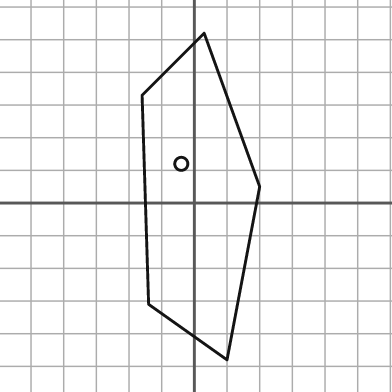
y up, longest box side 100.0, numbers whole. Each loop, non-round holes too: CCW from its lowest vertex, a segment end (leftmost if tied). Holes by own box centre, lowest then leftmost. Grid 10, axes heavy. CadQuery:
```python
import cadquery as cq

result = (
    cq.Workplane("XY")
    .moveTo(10.0, -48.0)
    .lineTo(20.0, 5.0)
    .lineTo(3.0, 52.0)
    .lineTo(-16.0, 33.0)
    .lineTo(-14.0, -31.0)
    .close()
    .moveTo(-4.0, 12.0)
    .circle(2.0)
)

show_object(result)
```